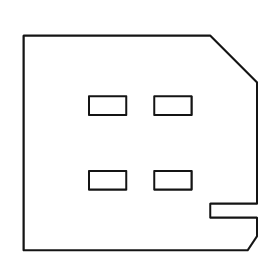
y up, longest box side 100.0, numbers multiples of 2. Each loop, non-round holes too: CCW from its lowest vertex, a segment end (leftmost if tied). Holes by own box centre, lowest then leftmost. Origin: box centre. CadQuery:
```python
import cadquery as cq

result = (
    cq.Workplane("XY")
    .moveTo(-50.0, -46.0)
    .lineTo(46.0, -46.0)
    .lineTo(50.0, -40.0)
    .lineTo(50.0, -32.0)
    .lineTo(30.0, -32.0)
    .lineTo(30.0, -26.0)
    .lineTo(50.0, -26.0)
    .lineTo(50.0, 26.0)
    .lineTo(30.0, 46.0)
    .lineTo(-50.0, 46.0)
    .close()
    .moveTo(-22.0, -20.0)
    .lineTo(-6.0, -20.0)
    .lineTo(-6.0, -12.0)
    .lineTo(-22.0, -12.0)
    .close()
    .moveTo(6.0, -20.0)
    .lineTo(22.0, -20.0)
    .lineTo(22.0, -12.0)
    .lineTo(6.0, -12.0)
    .close()
    .moveTo(-22.0, 12.0)
    .lineTo(-6.0, 12.0)
    .lineTo(-6.0, 20.0)
    .lineTo(-22.0, 20.0)
    .close()
    .moveTo(6.0, 12.0)
    .lineTo(22.0, 12.0)
    .lineTo(22.0, 20.0)
    .lineTo(6.0, 20.0)
    .close()
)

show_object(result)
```